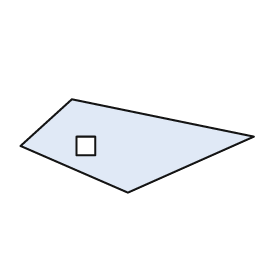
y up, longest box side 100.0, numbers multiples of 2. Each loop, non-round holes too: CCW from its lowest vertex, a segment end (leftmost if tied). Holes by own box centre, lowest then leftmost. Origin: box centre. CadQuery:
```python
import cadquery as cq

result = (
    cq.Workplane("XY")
    .moveTo(-4.0, -20.0)
    .lineTo(50.0, 4.0)
    .lineTo(-28.0, 20.0)
    .lineTo(-50.0, 0.0)
    .close()
    .moveTo(-26.0, -4.0)
    .lineTo(-18.0, -4.0)
    .lineTo(-18.0, 4.0)
    .lineTo(-26.0, 4.0)
    .close()
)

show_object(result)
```